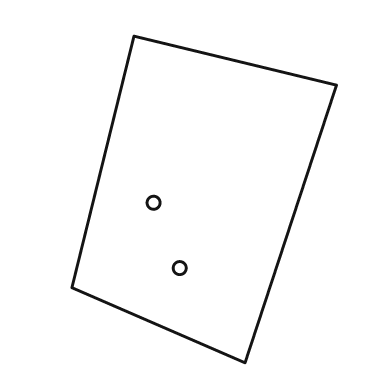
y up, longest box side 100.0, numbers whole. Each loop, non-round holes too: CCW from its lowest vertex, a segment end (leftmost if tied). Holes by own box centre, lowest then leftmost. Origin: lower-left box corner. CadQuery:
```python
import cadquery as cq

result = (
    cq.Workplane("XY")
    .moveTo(53.0, 0.0)
    .lineTo(81.0, 85.0)
    .lineTo(19.0, 100.0)
    .lineTo(0.0, 23.0)
    .close()
    .moveTo(33.0, 29.0)
    .circle(2.0)
    .moveTo(25.0, 49.0)
    .circle(2.0)
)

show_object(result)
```